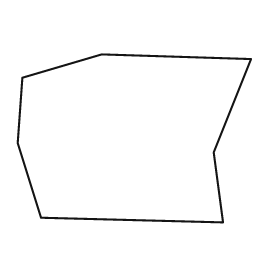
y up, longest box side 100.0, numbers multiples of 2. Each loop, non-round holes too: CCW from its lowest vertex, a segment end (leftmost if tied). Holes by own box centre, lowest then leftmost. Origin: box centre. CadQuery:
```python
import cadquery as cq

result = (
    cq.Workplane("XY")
    .moveTo(38.0, -36.0)
    .lineTo(34.0, -6.0)
    .lineTo(50.0, 34.0)
    .lineTo(-14.0, 36.0)
    .lineTo(-48.0, 26.0)
    .lineTo(-50.0, -2.0)
    .lineTo(-40.0, -34.0)
    .close()
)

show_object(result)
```